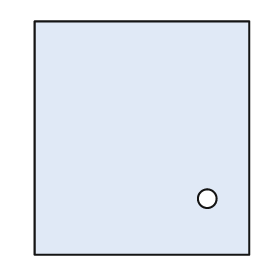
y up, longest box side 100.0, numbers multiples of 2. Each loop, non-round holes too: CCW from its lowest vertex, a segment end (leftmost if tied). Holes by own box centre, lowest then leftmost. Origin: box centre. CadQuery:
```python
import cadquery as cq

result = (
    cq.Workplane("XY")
    .moveTo(-46.0, -50.0)
    .lineTo(46.0, -50.0)
    .lineTo(46.0, 50.0)
    .lineTo(-46.0, 50.0)
    .close()
    .moveTo(28.0, -26.0)
    .circle(4.0)
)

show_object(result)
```